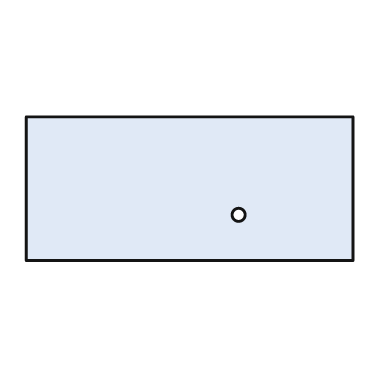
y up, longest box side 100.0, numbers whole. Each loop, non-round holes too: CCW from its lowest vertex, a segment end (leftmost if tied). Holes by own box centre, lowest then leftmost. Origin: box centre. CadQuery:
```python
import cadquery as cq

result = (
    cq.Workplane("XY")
    .moveTo(-50.0, -22.0)
    .lineTo(50.0, -22.0)
    .lineTo(50.0, 22.0)
    .lineTo(-50.0, 22.0)
    .close()
    .moveTo(15.0, -8.0)
    .circle(2.0)
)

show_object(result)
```